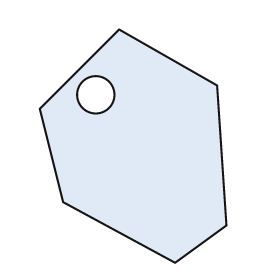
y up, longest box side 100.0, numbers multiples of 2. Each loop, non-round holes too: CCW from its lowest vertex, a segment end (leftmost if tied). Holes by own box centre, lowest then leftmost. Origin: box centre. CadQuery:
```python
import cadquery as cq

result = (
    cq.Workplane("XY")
    .moveTo(18.0, -50.0)
    .lineTo(40.0, -34.0)
    .lineTo(36.0, 26.0)
    .lineTo(-6.0, 50.0)
    .lineTo(-40.0, 16.0)
    .lineTo(-30.0, -24.0)
    .close()
    .moveTo(-16.0, 22.0)
    .circle(8.0)
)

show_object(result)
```